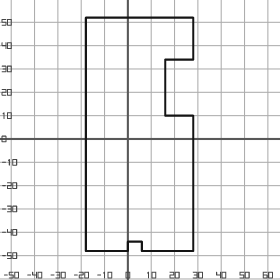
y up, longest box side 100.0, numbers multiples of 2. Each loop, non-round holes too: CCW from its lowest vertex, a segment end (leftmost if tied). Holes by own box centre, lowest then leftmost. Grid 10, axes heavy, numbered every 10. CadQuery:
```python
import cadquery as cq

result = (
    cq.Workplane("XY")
    .moveTo(-18.0, -48.0)
    .lineTo(0.0, -48.0)
    .lineTo(0.0, -44.0)
    .lineTo(6.0, -44.0)
    .lineTo(6.0, -48.0)
    .lineTo(28.0, -48.0)
    .lineTo(28.0, 10.0)
    .lineTo(16.0, 10.0)
    .lineTo(16.0, 34.0)
    .lineTo(28.0, 34.0)
    .lineTo(28.0, 52.0)
    .lineTo(-18.0, 52.0)
    .close()
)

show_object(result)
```